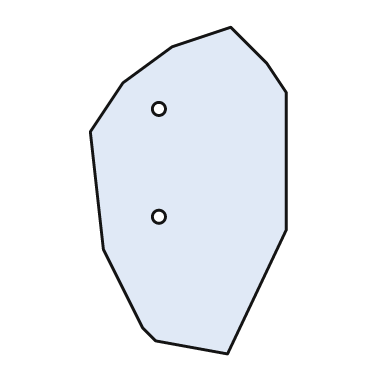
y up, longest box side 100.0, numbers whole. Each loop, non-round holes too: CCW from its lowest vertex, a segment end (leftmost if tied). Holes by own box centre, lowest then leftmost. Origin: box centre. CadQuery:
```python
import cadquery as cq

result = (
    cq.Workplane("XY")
    .moveTo(12.0, -50.0)
    .lineTo(30.0, -12.0)
    .lineTo(30.0, 30.0)
    .lineTo(24.0, 39.0)
    .lineTo(13.0, 50.0)
    .lineTo(-5.0, 44.0)
    .lineTo(-20.0, 33.0)
    .lineTo(-30.0, 18.0)
    .lineTo(-26.0, -18.0)
    .lineTo(-14.0, -42.0)
    .lineTo(-10.0, -46.0)
    .close()
    .moveTo(-9.0, -8.0)
    .circle(2.0)
    .moveTo(-9.0, 25.0)
    .circle(2.0)
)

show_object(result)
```